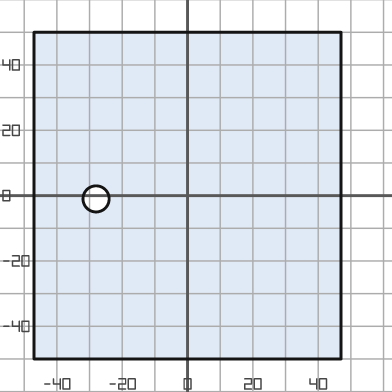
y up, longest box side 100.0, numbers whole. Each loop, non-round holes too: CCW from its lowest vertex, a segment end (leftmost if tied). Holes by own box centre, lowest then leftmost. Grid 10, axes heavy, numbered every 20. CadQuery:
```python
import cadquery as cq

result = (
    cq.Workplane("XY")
    .moveTo(-47.0, -50.0)
    .lineTo(47.0, -50.0)
    .lineTo(47.0, 50.0)
    .lineTo(-47.0, 50.0)
    .close()
    .moveTo(-28.0, -1.0)
    .circle(4.0)
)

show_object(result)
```